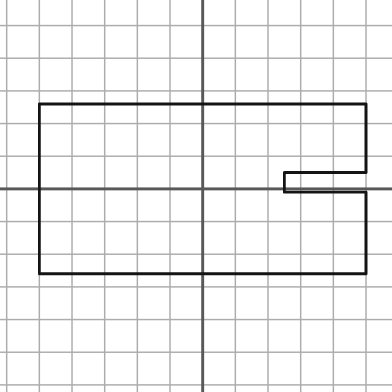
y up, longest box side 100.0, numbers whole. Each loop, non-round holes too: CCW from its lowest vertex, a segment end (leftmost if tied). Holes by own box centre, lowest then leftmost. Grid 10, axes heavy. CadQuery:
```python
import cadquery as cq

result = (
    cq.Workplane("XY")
    .moveTo(-50.0, -26.0)
    .lineTo(50.0, -26.0)
    .lineTo(50.0, -1.0)
    .lineTo(25.0, -1.0)
    .lineTo(25.0, 5.0)
    .lineTo(50.0, 5.0)
    .lineTo(50.0, 26.0)
    .lineTo(-50.0, 26.0)
    .close()
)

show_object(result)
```